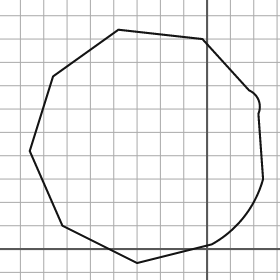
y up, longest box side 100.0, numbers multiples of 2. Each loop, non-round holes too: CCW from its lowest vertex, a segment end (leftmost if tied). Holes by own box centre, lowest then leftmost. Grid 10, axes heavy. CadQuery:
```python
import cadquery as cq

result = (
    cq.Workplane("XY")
    .moveTo(-30.0, -6.0)
    .lineTo(2.0, 2.0)
    .threePointArc((16.0, 14.0), (24.0, 30.0))
    .lineTo(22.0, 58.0)
    .threePointArc((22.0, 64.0), (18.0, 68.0))
    .lineTo(-2.0, 90.0)
    .lineTo(-38.0, 94.0)
    .lineTo(-66.0, 74.0)
    .lineTo(-76.0, 42.0)
    .lineTo(-62.0, 10.0)
    .close()
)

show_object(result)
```